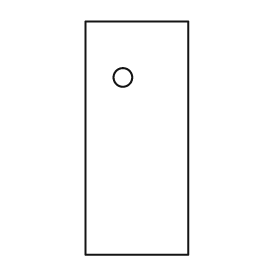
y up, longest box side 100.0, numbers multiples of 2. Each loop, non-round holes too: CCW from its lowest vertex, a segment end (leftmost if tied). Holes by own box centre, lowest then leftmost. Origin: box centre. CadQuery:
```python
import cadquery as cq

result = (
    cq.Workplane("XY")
    .moveTo(-22.0, -50.0)
    .lineTo(22.0, -50.0)
    .lineTo(22.0, 50.0)
    .lineTo(-22.0, 50.0)
    .close()
    .moveTo(-6.0, 26.0)
    .circle(4.0)
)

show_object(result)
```